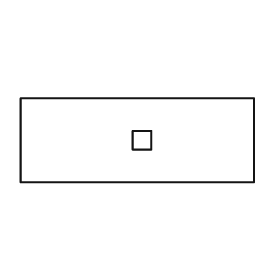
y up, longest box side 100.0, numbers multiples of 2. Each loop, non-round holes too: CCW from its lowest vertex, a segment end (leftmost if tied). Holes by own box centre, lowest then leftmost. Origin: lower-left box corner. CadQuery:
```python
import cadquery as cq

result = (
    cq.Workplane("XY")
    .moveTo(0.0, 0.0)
    .lineTo(100.0, 0.0)
    .lineTo(100.0, 36.0)
    .lineTo(0.0, 36.0)
    .close()
    .moveTo(48.0, 14.0)
    .lineTo(56.0, 14.0)
    .lineTo(56.0, 22.0)
    .lineTo(48.0, 22.0)
    .close()
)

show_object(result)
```